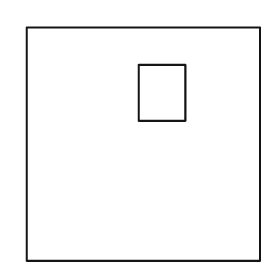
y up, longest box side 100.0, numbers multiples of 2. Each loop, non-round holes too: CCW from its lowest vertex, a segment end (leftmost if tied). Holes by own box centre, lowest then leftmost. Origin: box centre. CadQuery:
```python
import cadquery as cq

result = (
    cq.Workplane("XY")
    .moveTo(-50.0, -50.0)
    .lineTo(50.0, -50.0)
    .lineTo(50.0, 50.0)
    .lineTo(-50.0, 50.0)
    .close()
    .moveTo(-2.0, 10.0)
    .lineTo(18.0, 10.0)
    .lineTo(18.0, 34.0)
    .lineTo(-2.0, 34.0)
    .close()
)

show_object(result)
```